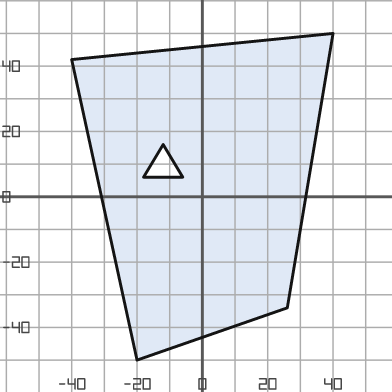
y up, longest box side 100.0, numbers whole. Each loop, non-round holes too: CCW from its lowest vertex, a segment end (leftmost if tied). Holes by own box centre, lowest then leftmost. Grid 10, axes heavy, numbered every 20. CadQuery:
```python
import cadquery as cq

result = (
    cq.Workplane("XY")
    .moveTo(-20.0, -50.0)
    .lineTo(26.0, -34.0)
    .lineTo(40.0, 50.0)
    .lineTo(-40.0, 42.0)
    .close()
    .moveTo(-18.0, 6.0)
    .lineTo(-6.0, 6.0)
    .lineTo(-12.0, 16.0)
    .close()
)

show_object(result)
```